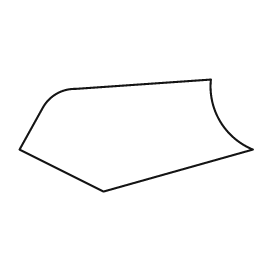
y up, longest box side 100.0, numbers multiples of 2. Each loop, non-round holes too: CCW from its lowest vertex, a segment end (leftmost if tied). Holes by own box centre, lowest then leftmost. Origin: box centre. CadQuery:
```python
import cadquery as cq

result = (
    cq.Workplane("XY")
    .moveTo(-14.0, -24.0)
    .lineTo(50.0, -6.0)
    .threePointArc((36.0, 6.0), (32.0, 24.0))
    .lineTo(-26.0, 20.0)
    .threePointArc((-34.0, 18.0), (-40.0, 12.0))
    .lineTo(-50.0, -6.0)
    .close()
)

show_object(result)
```